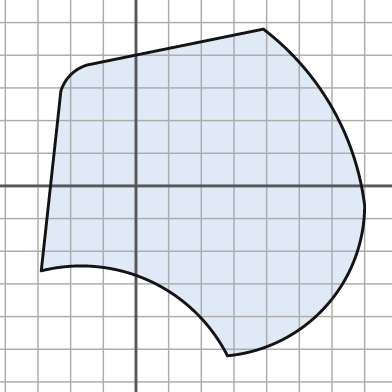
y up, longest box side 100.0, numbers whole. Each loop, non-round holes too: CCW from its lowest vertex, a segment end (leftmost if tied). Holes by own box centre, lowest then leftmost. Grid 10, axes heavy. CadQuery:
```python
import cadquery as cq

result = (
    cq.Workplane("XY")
    .moveTo(28.0, -52.0)
    .threePointArc((58.0, -37.0), (70.0, -6.0))
    .threePointArc((60.0, 24.0), (39.0, 48.0))
    .lineTo(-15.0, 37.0)
    .threePointArc((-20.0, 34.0), (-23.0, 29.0))
    .lineTo(-29.0, -26.0)
    .threePointArc((4.0, -29.0), (28.0, -52.0))
    .close()
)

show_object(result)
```